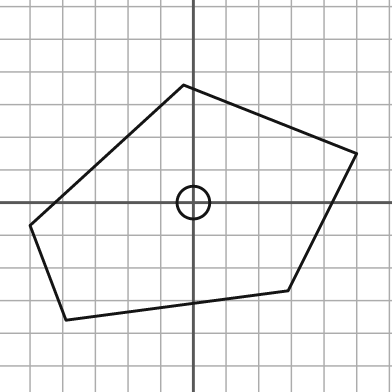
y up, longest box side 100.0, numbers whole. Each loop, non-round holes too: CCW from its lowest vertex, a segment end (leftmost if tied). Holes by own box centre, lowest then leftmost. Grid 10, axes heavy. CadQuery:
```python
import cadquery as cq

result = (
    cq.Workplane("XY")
    .moveTo(-39.0, -36.0)
    .lineTo(29.0, -27.0)
    .lineTo(50.0, 15.0)
    .lineTo(-3.0, 36.0)
    .lineTo(-50.0, -7.0)
    .close()
    .moveTo(0.0, 0.0)
    .circle(5.0)
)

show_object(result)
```